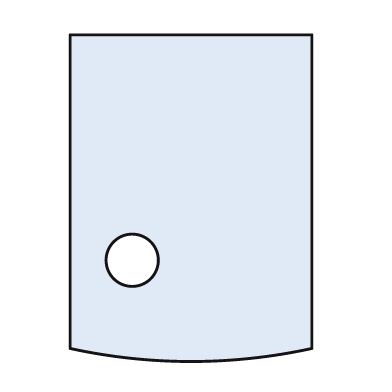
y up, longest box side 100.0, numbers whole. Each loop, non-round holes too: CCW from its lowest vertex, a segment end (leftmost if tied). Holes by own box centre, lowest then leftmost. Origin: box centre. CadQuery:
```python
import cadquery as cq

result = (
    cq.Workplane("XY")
    .moveTo(-37.0, -46.0)
    .threePointArc((0.0, -50.0), (37.0, -46.0))
    .lineTo(37.0, 50.0)
    .lineTo(-37.0, 50.0)
    .close()
    .moveTo(-18.0, -19.0)
    .circle(8.0)
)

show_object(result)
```